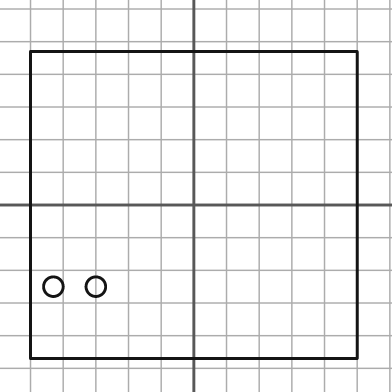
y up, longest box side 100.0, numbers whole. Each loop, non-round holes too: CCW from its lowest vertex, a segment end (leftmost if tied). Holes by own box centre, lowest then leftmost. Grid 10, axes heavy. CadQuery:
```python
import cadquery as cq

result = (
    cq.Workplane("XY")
    .moveTo(-50.0, -47.0)
    .lineTo(50.0, -47.0)
    .lineTo(50.0, 47.0)
    .lineTo(-50.0, 47.0)
    .close()
    .moveTo(-43.0, -25.0)
    .circle(3.0)
    .moveTo(-30.0, -25.0)
    .circle(3.0)
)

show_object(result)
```